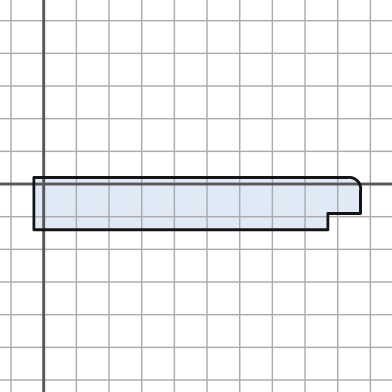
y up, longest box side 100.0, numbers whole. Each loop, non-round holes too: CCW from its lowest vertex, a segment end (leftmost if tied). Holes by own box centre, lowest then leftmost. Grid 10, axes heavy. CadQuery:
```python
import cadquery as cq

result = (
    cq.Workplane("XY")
    .moveTo(-3.0, -14.0)
    .lineTo(87.0, -14.0)
    .lineTo(87.0, -9.0)
    .lineTo(97.0, -9.0)
    .lineTo(97.0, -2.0)
    .threePointArc((96.0, 1.0), (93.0, 2.0))
    .lineTo(-3.0, 2.0)
    .close()
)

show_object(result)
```